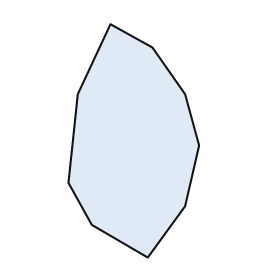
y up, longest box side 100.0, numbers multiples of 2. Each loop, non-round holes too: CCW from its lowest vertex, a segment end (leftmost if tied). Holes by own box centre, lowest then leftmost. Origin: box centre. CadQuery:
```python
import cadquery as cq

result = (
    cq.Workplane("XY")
    .moveTo(6.0, -50.0)
    .lineTo(22.0, -28.0)
    .lineTo(28.0, -2.0)
    .lineTo(22.0, 20.0)
    .lineTo(8.0, 40.0)
    .lineTo(-10.0, 50.0)
    .lineTo(-24.0, 20.0)
    .lineTo(-28.0, -18.0)
    .lineTo(-18.0, -36.0)
    .close()
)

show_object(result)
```